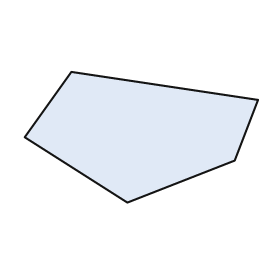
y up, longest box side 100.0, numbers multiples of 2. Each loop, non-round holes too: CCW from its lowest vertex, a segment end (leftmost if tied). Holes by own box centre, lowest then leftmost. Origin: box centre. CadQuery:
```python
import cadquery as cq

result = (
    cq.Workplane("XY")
    .moveTo(-6.0, -28.0)
    .lineTo(40.0, -10.0)
    .lineTo(50.0, 16.0)
    .lineTo(-30.0, 28.0)
    .lineTo(-50.0, 0.0)
    .close()
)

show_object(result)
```